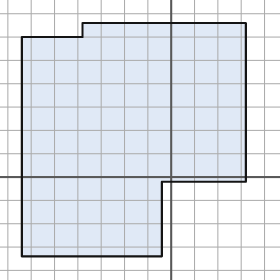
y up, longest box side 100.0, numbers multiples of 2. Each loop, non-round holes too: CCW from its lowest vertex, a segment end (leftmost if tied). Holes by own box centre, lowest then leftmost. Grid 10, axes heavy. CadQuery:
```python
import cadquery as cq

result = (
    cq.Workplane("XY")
    .moveTo(-64.0, -34.0)
    .lineTo(-4.0, -34.0)
    .lineTo(-4.0, -2.0)
    .lineTo(32.0, -2.0)
    .lineTo(32.0, 66.0)
    .lineTo(-38.0, 66.0)
    .lineTo(-38.0, 60.0)
    .lineTo(-64.0, 60.0)
    .close()
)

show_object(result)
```